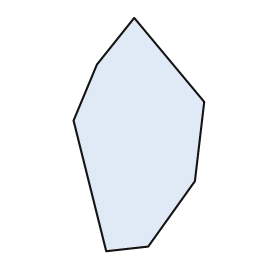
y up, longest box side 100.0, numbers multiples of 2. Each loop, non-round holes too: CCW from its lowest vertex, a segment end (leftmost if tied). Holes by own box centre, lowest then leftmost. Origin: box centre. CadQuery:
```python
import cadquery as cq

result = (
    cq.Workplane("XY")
    .moveTo(-14.0, -50.0)
    .lineTo(4.0, -48.0)
    .lineTo(24.0, -20.0)
    .lineTo(28.0, 14.0)
    .lineTo(-2.0, 50.0)
    .lineTo(-18.0, 30.0)
    .lineTo(-28.0, 6.0)
    .close()
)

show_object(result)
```